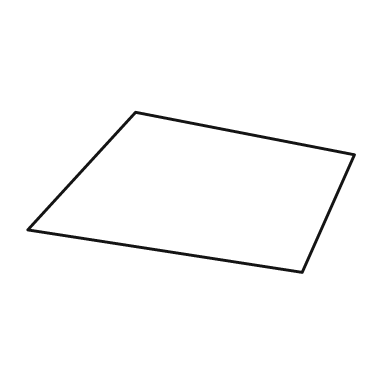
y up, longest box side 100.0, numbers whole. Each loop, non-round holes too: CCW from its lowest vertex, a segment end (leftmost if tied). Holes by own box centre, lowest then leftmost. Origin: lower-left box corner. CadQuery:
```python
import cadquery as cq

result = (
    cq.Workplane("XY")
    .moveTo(84.0, 0.0)
    .lineTo(100.0, 36.0)
    .lineTo(33.0, 49.0)
    .lineTo(0.0, 13.0)
    .close()
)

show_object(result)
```